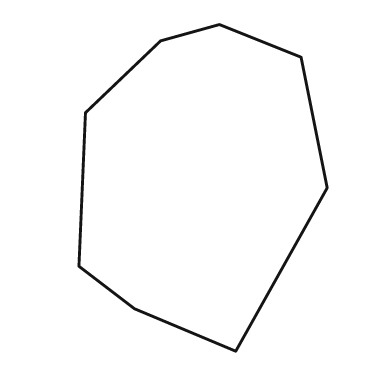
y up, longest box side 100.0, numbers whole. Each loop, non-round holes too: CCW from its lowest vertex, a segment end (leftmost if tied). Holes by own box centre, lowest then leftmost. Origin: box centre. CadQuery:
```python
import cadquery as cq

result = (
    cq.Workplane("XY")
    .moveTo(10.0, -50.0)
    .lineTo(38.0, 0.0)
    .lineTo(30.0, 40.0)
    .lineTo(5.0, 50.0)
    .lineTo(-13.0, 45.0)
    .lineTo(-36.0, 23.0)
    .lineTo(-38.0, -24.0)
    .lineTo(-21.0, -37.0)
    .close()
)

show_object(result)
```